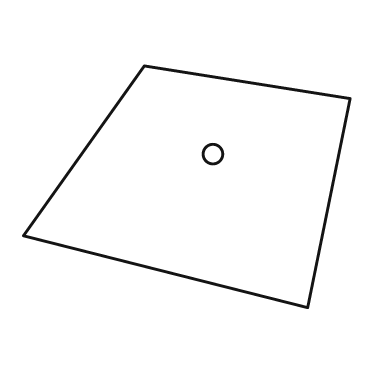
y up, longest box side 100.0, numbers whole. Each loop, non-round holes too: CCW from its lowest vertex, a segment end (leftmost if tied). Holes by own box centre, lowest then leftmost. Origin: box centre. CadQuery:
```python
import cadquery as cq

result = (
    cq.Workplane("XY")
    .moveTo(37.0, -37.0)
    .lineTo(50.0, 27.0)
    .lineTo(-13.0, 37.0)
    .lineTo(-50.0, -15.0)
    .close()
    .moveTo(8.0, 10.0)
    .circle(3.0)
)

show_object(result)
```